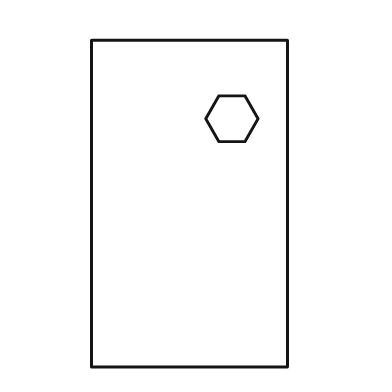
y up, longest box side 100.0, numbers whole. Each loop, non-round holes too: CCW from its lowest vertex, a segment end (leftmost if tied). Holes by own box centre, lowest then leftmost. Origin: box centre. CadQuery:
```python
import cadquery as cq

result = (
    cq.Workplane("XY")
    .moveTo(-30.0, -50.0)
    .lineTo(30.0, -50.0)
    .lineTo(30.0, 50.0)
    .lineTo(-30.0, 50.0)
    .close()
    .moveTo(9.0, 19.0)
    .lineTo(17.0, 19.0)
    .lineTo(21.0, 26.0)
    .lineTo(17.0, 33.0)
    .lineTo(9.0, 33.0)
    .lineTo(5.0, 26.0)
    .close()
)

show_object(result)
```